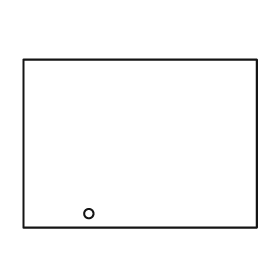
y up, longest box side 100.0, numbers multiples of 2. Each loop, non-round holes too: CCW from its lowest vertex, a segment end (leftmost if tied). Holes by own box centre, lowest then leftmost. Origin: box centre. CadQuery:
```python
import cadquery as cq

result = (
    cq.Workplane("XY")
    .moveTo(-50.0, -36.0)
    .lineTo(50.0, -36.0)
    .lineTo(50.0, 36.0)
    .lineTo(-50.0, 36.0)
    .close()
    .moveTo(-22.0, -30.0)
    .circle(2.0)
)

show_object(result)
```